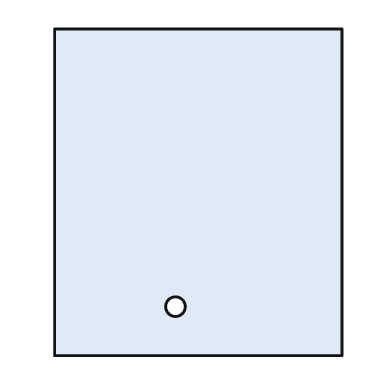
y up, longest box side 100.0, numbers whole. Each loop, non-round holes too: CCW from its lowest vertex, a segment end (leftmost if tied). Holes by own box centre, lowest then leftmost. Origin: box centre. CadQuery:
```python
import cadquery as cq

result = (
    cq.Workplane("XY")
    .moveTo(-44.0, -50.0)
    .lineTo(44.0, -50.0)
    .lineTo(44.0, 50.0)
    .lineTo(-44.0, 50.0)
    .close()
    .moveTo(-7.0, -35.0)
    .circle(3.0)
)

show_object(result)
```